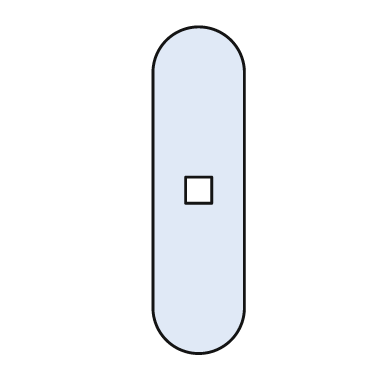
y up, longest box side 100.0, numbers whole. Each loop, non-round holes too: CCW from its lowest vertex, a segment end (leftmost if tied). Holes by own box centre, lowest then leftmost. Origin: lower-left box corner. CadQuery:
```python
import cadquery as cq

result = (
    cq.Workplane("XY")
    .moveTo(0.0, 14.0)
    .threePointArc((14.0, 0.0), (28.0, 14.0))
    .lineTo(28.0, 86.0)
    .threePointArc((14.0, 100.0), (0.0, 86.0))
    .close()
    .moveTo(10.0, 46.0)
    .lineTo(18.0, 46.0)
    .lineTo(18.0, 54.0)
    .lineTo(10.0, 54.0)
    .close()
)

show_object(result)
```